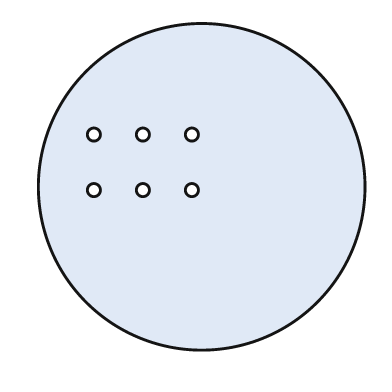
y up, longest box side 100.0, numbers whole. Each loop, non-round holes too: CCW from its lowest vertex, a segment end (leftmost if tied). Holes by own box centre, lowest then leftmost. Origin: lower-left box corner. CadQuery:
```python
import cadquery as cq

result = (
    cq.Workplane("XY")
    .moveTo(50.0, 50.0)
    .circle(50.0)
    .moveTo(17.0, 49.0)
    .circle(2.0)
    .moveTo(32.0, 49.0)
    .circle(2.0)
    .moveTo(47.0, 49.0)
    .circle(2.0)
    .moveTo(17.0, 66.0)
    .circle(2.0)
    .moveTo(32.0, 66.0)
    .circle(2.0)
    .moveTo(47.0, 66.0)
    .circle(2.0)
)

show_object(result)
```